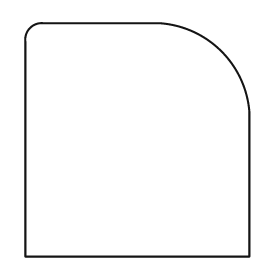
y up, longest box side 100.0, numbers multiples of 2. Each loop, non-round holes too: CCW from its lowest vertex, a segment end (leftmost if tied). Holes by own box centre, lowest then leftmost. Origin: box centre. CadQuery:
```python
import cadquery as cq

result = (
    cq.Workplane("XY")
    .moveTo(-48.0, -50.0)
    .lineTo(48.0, -50.0)
    .lineTo(48.0, 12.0)
    .threePointArc((36.0, 38.0), (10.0, 50.0))
    .lineTo(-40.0, 50.0)
    .threePointArc((-46.0, 48.0), (-48.0, 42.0))
    .close()
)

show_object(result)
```